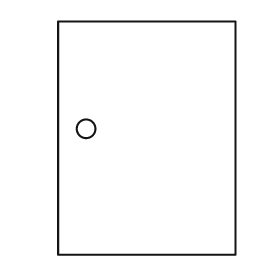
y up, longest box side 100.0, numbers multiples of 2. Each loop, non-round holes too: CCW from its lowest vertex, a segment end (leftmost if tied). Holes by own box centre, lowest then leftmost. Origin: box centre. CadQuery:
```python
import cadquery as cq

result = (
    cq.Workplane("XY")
    .moveTo(-38.0, -50.0)
    .lineTo(38.0, -50.0)
    .lineTo(38.0, 50.0)
    .lineTo(-38.0, 50.0)
    .close()
    .moveTo(-26.0, 4.0)
    .circle(4.0)
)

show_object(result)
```